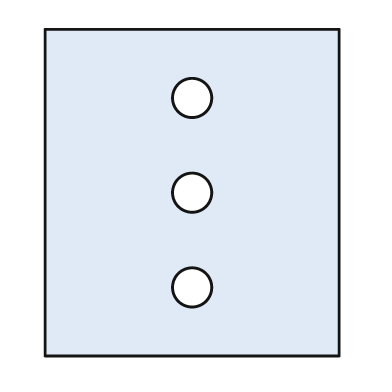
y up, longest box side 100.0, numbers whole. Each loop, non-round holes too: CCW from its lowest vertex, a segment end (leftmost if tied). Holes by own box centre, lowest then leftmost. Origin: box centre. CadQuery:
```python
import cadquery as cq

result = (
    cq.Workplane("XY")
    .moveTo(-45.0, -50.0)
    .lineTo(45.0, -50.0)
    .lineTo(45.0, 50.0)
    .lineTo(-45.0, 50.0)
    .close()
    .moveTo(0.0, -29.0)
    .circle(6.0)
    .moveTo(0.0, 0.0)
    .circle(6.0)
    .moveTo(0.0, 29.0)
    .circle(6.0)
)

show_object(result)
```